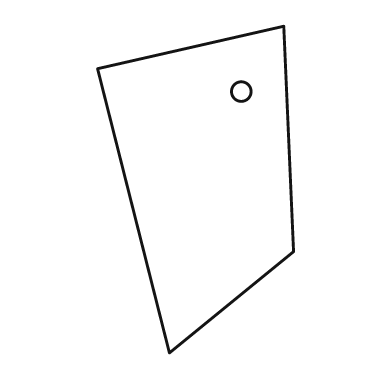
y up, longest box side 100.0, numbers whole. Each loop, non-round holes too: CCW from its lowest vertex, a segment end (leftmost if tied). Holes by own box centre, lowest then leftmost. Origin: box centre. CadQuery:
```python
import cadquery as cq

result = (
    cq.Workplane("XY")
    .moveTo(-8.0, -50.0)
    .lineTo(30.0, -19.0)
    .lineTo(27.0, 50.0)
    .lineTo(-30.0, 37.0)
    .close()
    .moveTo(14.0, 30.0)
    .circle(3.0)
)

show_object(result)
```